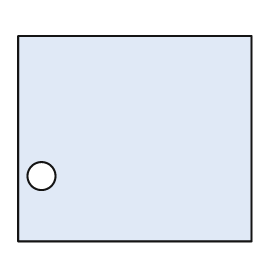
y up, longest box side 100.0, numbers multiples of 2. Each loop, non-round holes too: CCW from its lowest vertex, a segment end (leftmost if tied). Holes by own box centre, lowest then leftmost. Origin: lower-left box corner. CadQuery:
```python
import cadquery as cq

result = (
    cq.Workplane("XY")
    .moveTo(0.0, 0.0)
    .lineTo(100.0, 0.0)
    .lineTo(100.0, 88.0)
    .lineTo(0.0, 88.0)
    .close()
    .moveTo(10.0, 28.0)
    .circle(6.0)
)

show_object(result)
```